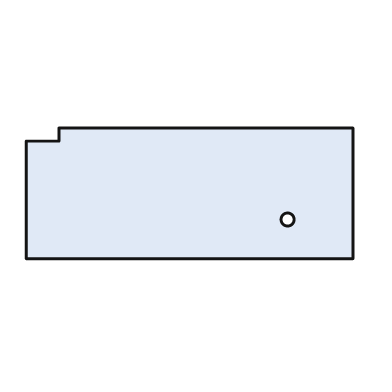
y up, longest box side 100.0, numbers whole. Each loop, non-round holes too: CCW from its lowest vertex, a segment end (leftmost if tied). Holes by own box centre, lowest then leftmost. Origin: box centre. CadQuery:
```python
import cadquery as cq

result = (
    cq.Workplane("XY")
    .moveTo(-50.0, -20.0)
    .lineTo(50.0, -20.0)
    .lineTo(50.0, 20.0)
    .lineTo(-40.0, 20.0)
    .lineTo(-40.0, 16.0)
    .lineTo(-50.0, 16.0)
    .close()
    .moveTo(30.0, -8.0)
    .circle(2.0)
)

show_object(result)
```